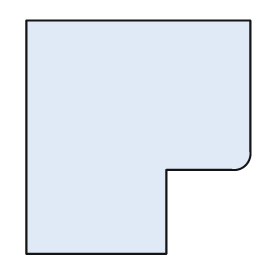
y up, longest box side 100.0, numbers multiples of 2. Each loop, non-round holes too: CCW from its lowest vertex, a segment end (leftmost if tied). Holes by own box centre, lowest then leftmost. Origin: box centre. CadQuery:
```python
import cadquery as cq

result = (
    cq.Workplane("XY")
    .moveTo(-48.0, -50.0)
    .lineTo(12.0, -50.0)
    .lineTo(12.0, -14.0)
    .lineTo(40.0, -14.0)
    .threePointArc((46.0, -12.0), (48.0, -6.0))
    .lineTo(48.0, 50.0)
    .lineTo(-48.0, 50.0)
    .close()
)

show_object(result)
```